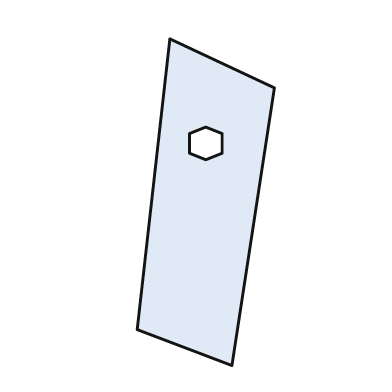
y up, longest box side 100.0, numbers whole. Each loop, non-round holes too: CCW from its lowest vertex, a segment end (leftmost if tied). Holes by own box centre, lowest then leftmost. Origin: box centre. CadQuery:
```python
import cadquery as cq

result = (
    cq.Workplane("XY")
    .moveTo(8.0, -50.0)
    .lineTo(21.0, 35.0)
    .lineTo(-11.0, 50.0)
    .lineTo(-21.0, -39.0)
    .close()
    .moveTo(0.0, 13.0)
    .lineTo(5.0, 15.0)
    .lineTo(5.0, 21.0)
    .lineTo(0.0, 23.0)
    .lineTo(-5.0, 21.0)
    .lineTo(-5.0, 15.0)
    .close()
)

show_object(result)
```